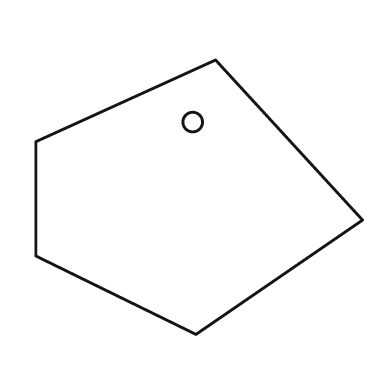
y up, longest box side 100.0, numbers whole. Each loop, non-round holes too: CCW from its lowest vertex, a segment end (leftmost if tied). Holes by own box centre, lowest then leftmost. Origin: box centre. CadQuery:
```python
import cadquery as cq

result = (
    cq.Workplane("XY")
    .moveTo(-1.0, -42.0)
    .lineTo(50.0, -7.0)
    .lineTo(5.0, 42.0)
    .lineTo(-50.0, 17.0)
    .lineTo(-50.0, -18.0)
    .close()
    .moveTo(-2.0, 23.0)
    .circle(3.0)
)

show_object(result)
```